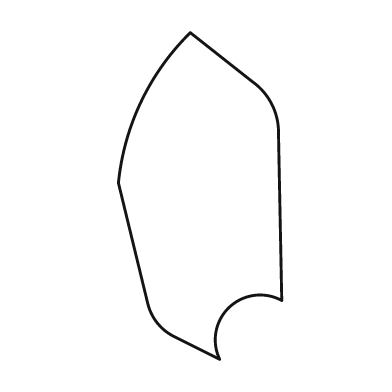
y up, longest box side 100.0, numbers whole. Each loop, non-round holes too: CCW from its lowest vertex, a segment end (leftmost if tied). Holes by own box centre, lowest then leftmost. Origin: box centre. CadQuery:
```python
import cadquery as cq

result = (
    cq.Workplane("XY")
    .moveTo(6.0, -50.0)
    .threePointArc((9.0, -34.0), (25.0, -32.0))
    .lineTo(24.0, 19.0)
    .threePointArc((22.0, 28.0), (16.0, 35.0))
    .lineTo(-3.0, 50.0)
    .threePointArc((-18.0, 29.0), (-25.0, 4.0))
    .lineTo(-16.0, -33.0)
    .threePointArc((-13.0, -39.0), (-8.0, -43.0))
    .close()
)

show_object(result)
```